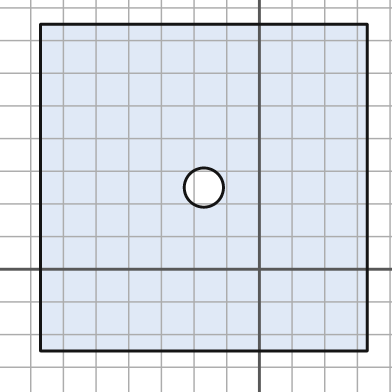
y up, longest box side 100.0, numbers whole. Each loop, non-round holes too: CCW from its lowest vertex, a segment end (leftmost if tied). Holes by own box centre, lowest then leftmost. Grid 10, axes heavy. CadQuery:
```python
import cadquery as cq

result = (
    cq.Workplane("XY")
    .moveTo(-67.0, -25.0)
    .lineTo(33.0, -25.0)
    .lineTo(33.0, 75.0)
    .lineTo(-67.0, 75.0)
    .close()
    .moveTo(-17.0, 25.0)
    .circle(6.0)
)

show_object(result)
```